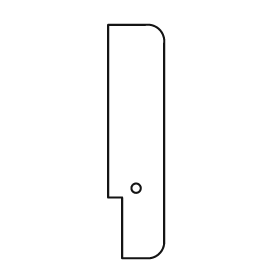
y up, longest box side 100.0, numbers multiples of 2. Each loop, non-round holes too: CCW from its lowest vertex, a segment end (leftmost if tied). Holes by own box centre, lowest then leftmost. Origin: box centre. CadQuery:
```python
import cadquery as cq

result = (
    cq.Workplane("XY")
    .moveTo(-6.0, -50.0)
    .lineTo(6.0, -50.0)
    .threePointArc((10.0, -48.0), (12.0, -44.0))
    .lineTo(12.0, 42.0)
    .threePointArc((10.0, 48.0), (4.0, 50.0))
    .lineTo(-12.0, 50.0)
    .lineTo(-12.0, -24.0)
    .lineTo(-6.0, -24.0)
    .close()
    .moveTo(0.0, -20.0)
    .circle(2.0)
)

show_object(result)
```